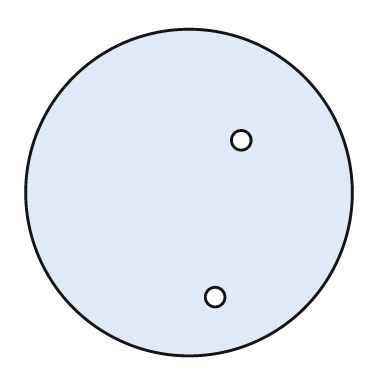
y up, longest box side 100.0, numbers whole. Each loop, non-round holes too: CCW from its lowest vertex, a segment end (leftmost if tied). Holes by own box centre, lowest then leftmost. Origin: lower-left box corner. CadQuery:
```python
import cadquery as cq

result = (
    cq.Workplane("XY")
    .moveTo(50.0, 50.0)
    .circle(50.0)
    .moveTo(58.0, 18.0)
    .circle(3.0)
    .moveTo(66.0, 66.0)
    .circle(3.0)
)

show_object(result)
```